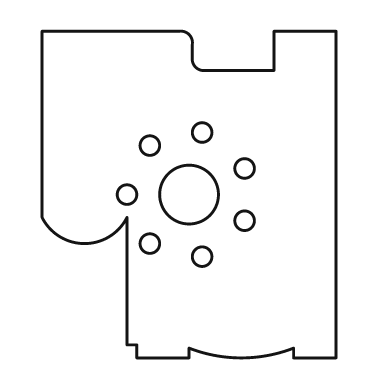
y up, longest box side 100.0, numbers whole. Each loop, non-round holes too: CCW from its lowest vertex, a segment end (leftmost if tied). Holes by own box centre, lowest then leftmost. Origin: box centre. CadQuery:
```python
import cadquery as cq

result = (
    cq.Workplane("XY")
    .moveTo(-16.0, -50.0)
    .lineTo(0.0, -50.0)
    .lineTo(0.0, -47.0)
    .threePointArc((16.0, -50.0), (32.0, -47.0))
    .lineTo(32.0, -50.0)
    .lineTo(45.0, -50.0)
    .lineTo(45.0, 50.0)
    .lineTo(26.0, 50.0)
    .lineTo(26.0, 38.0)
    .lineTo(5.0, 38.0)
    .threePointArc((2.0, 39.0), (1.0, 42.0))
    .lineTo(1.0, 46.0)
    .threePointArc((0.0, 49.0), (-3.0, 50.0))
    .lineTo(-45.0, 50.0)
    .lineTo(-45.0, -7.0)
    .threePointArc((-32.0, -15.0), (-19.0, -7.0))
    .lineTo(-19.0, -46.0)
    .lineTo(-16.0, -46.0)
    .close()
    .moveTo(4.0, -19.0)
    .circle(3.0)
    .moveTo(-12.0, -15.0)
    .circle(3.0)
    .moveTo(17.0, -8.0)
    .circle(3.0)
    .moveTo(-19.0, 0.0)
    .circle(3.0)
    .moveTo(0.0, 0.0)
    .circle(9.0)
    .moveTo(17.0, 8.0)
    .circle(3.0)
    .moveTo(-12.0, 15.0)
    .circle(3.0)
    .moveTo(4.0, 19.0)
    .circle(3.0)
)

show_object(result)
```